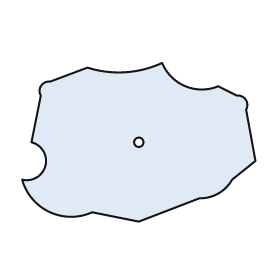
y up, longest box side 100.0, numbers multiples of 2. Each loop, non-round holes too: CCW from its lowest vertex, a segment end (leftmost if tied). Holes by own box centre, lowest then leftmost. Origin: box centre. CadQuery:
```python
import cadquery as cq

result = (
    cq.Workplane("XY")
    .moveTo(0.0, -34.0)
    .lineTo(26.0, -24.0)
    .threePointArc((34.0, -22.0), (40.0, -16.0))
    .lineTo(50.0, -8.0)
    .lineTo(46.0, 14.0)
    .threePointArc((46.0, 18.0), (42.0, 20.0))
    .lineTo(34.0, 24.0)
    .threePointArc((20.0, 24.0), (10.0, 34.0))
    .threePointArc((-6.0, 30.0), (-22.0, 32.0))
    .lineTo(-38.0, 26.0)
    .threePointArc((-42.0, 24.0), (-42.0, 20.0))
    .lineTo(-46.0, 0.0)
    .threePointArc((-40.0, -10.0), (-50.0, -16.0))
    .threePointArc((-38.0, -30.0), (-20.0, -30.0))
    .close()
    .moveTo(0.0, 0.0)
    .circle(2.0)
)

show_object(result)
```